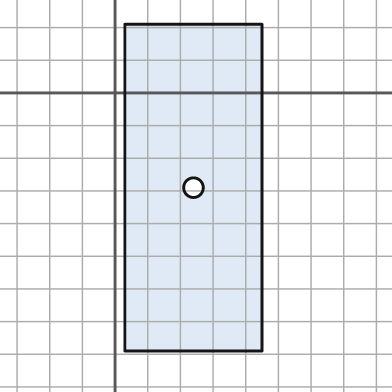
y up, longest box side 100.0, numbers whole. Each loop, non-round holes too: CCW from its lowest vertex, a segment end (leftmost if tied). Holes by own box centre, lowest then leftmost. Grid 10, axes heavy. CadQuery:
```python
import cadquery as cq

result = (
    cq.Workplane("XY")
    .moveTo(3.0, -79.0)
    .lineTo(45.0, -79.0)
    .lineTo(45.0, 21.0)
    .lineTo(3.0, 21.0)
    .close()
    .moveTo(24.0, -29.0)
    .circle(3.0)
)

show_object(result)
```